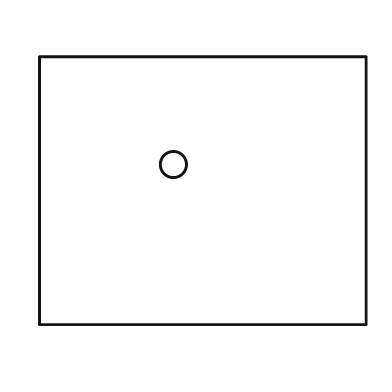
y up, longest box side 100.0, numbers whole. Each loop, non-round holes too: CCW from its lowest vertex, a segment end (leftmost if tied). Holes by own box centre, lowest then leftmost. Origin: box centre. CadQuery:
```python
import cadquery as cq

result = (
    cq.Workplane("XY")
    .moveTo(-50.0, -41.0)
    .lineTo(50.0, -41.0)
    .lineTo(50.0, 41.0)
    .lineTo(-50.0, 41.0)
    .close()
    .moveTo(-9.0, 8.0)
    .circle(4.0)
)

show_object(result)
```